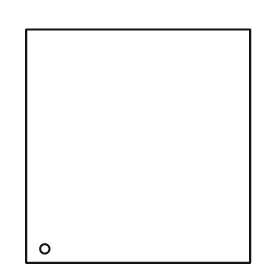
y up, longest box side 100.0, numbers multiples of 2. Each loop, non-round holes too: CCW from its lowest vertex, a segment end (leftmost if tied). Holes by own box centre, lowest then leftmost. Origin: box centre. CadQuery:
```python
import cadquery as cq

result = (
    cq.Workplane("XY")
    .moveTo(-48.0, -50.0)
    .lineTo(48.0, -50.0)
    .lineTo(48.0, 50.0)
    .lineTo(-48.0, 50.0)
    .close()
    .moveTo(-40.0, -44.0)
    .circle(2.0)
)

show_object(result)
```